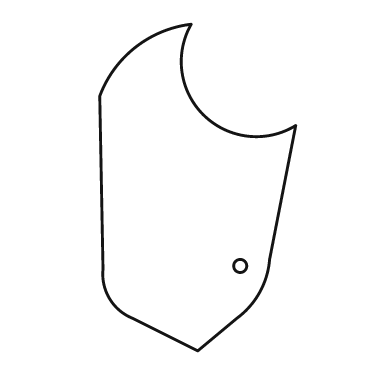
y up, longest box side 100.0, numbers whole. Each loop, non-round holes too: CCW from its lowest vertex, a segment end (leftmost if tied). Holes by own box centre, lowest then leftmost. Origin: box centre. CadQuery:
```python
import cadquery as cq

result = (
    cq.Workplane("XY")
    .moveTo(0.0, -50.0)
    .lineTo(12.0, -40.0)
    .threePointArc((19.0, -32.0), (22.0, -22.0))
    .lineTo(30.0, 19.0)
    .threePointArc((2.0, 22.0), (-2.0, 50.0))
    .threePointArc((-19.0, 43.0), (-30.0, 28.0))
    .lineTo(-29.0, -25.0)
    .threePointArc((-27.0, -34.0), (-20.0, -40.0))
    .close()
    .moveTo(13.0, -24.0)
    .circle(2.0)
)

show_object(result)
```